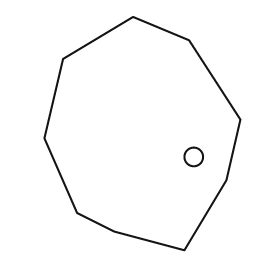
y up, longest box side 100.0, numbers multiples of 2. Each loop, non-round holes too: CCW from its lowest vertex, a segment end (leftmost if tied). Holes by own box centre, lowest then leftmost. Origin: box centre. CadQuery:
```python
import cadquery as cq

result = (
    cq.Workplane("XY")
    .moveTo(18.0, -50.0)
    .lineTo(36.0, -20.0)
    .lineTo(42.0, 6.0)
    .lineTo(20.0, 40.0)
    .lineTo(-4.0, 50.0)
    .lineTo(-34.0, 32.0)
    .lineTo(-42.0, -2.0)
    .lineTo(-28.0, -34.0)
    .lineTo(-12.0, -42.0)
    .close()
    .moveTo(22.0, -10.0)
    .circle(4.0)
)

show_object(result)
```